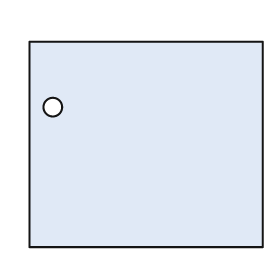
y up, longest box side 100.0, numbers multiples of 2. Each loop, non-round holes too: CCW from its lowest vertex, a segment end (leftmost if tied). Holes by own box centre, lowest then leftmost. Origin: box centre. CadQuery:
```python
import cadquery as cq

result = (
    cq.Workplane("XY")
    .moveTo(-50.0, -44.0)
    .lineTo(50.0, -44.0)
    .lineTo(50.0, 44.0)
    .lineTo(-50.0, 44.0)
    .close()
    .moveTo(-40.0, 16.0)
    .circle(4.0)
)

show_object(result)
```